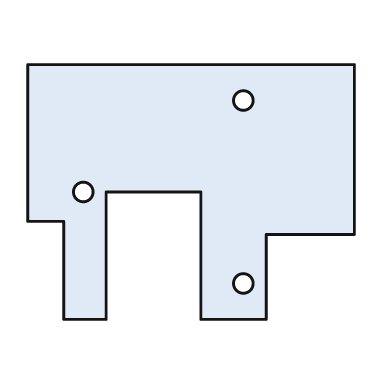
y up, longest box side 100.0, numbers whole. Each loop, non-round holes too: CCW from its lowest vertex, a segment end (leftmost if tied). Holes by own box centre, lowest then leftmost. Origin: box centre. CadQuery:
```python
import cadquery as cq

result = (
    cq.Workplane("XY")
    .moveTo(-39.0, -39.0)
    .lineTo(-26.0, -39.0)
    .lineTo(-26.0, 0.0)
    .lineTo(3.0, 0.0)
    .lineTo(3.0, -39.0)
    .lineTo(23.0, -39.0)
    .lineTo(23.0, -13.0)
    .lineTo(50.0, -13.0)
    .lineTo(50.0, 39.0)
    .lineTo(-50.0, 39.0)
    .lineTo(-50.0, -9.0)
    .lineTo(-39.0, -9.0)
    .close()
    .moveTo(16.0, -28.0)
    .circle(3.0)
    .moveTo(-33.0, 0.0)
    .circle(3.0)
    .moveTo(16.0, 28.0)
    .circle(3.0)
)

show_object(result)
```